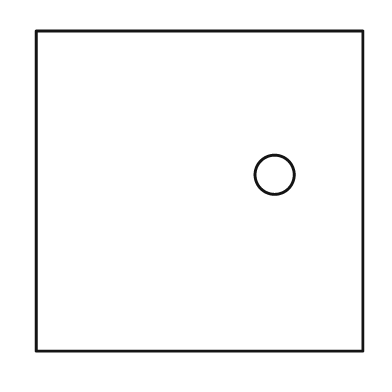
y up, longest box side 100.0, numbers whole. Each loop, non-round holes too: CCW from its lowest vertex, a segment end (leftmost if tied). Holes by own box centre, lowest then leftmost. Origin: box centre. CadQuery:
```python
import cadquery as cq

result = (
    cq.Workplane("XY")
    .moveTo(-50.0, -49.0)
    .lineTo(50.0, -49.0)
    .lineTo(50.0, 49.0)
    .lineTo(-50.0, 49.0)
    .close()
    .moveTo(23.0, 5.0)
    .circle(6.0)
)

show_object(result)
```